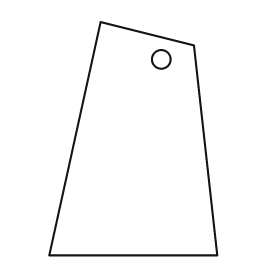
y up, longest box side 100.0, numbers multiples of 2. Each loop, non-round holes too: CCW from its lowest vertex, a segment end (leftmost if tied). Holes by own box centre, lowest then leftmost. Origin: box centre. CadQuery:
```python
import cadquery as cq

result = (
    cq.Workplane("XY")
    .moveTo(-36.0, -50.0)
    .lineTo(36.0, -50.0)
    .lineTo(26.0, 40.0)
    .lineTo(-14.0, 50.0)
    .close()
    .moveTo(12.0, 34.0)
    .circle(4.0)
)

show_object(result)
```